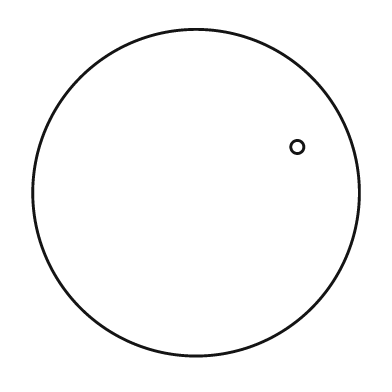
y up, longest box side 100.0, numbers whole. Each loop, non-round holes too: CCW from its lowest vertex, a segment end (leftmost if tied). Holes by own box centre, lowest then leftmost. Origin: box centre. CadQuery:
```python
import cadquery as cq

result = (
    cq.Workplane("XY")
    .moveTo(0.0, 0.0)
    .circle(50.0)
    .moveTo(31.0, 14.0)
    .circle(2.0)
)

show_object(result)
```